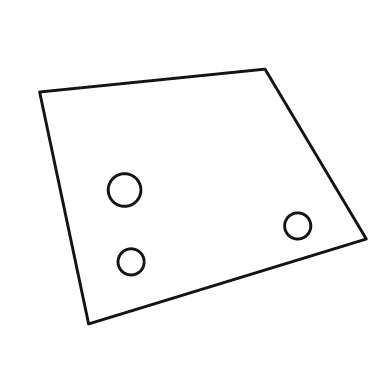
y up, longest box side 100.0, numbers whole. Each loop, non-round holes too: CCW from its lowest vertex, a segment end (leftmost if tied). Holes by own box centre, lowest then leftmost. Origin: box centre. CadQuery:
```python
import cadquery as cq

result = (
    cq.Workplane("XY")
    .moveTo(-35.0, -39.0)
    .lineTo(50.0, -13.0)
    .lineTo(19.0, 39.0)
    .lineTo(-50.0, 32.0)
    .close()
    .moveTo(-22.0, -20.0)
    .circle(4.0)
    .moveTo(29.0, -9.0)
    .circle(4.0)
    .moveTo(-24.0, 2.0)
    .circle(5.0)
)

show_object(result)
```